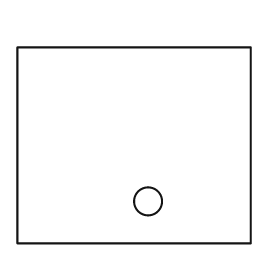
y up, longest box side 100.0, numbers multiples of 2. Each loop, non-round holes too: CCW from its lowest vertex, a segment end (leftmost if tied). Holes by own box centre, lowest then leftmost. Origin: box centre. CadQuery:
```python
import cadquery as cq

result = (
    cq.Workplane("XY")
    .moveTo(-50.0, -42.0)
    .lineTo(50.0, -42.0)
    .lineTo(50.0, 42.0)
    .lineTo(-50.0, 42.0)
    .close()
    .moveTo(6.0, -24.0)
    .circle(6.0)
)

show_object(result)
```